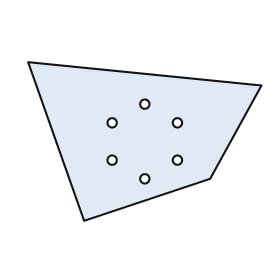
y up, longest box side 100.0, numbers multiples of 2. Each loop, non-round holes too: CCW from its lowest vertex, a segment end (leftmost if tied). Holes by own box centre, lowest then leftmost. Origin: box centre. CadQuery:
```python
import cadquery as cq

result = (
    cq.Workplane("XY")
    .moveTo(-26.0, -34.0)
    .lineTo(28.0, -16.0)
    .lineTo(50.0, 24.0)
    .lineTo(-50.0, 34.0)
    .close()
    .moveTo(0.0, -16.0)
    .circle(2.0)
    .moveTo(-14.0, -8.0)
    .circle(2.0)
    .moveTo(14.0, -8.0)
    .circle(2.0)
    .moveTo(-14.0, 8.0)
    .circle(2.0)
    .moveTo(14.0, 8.0)
    .circle(2.0)
    .moveTo(0.0, 16.0)
    .circle(2.0)
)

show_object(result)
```